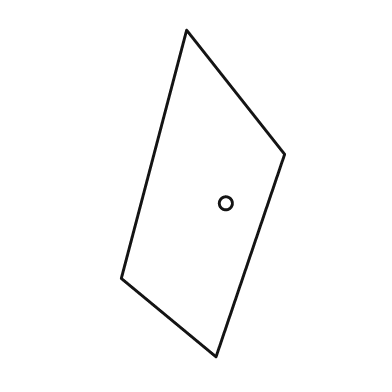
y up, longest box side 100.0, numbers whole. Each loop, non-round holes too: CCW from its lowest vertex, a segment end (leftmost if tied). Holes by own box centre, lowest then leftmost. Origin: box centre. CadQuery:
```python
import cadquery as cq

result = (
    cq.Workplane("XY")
    .moveTo(4.0, -50.0)
    .lineTo(25.0, 12.0)
    .lineTo(-5.0, 50.0)
    .lineTo(-25.0, -26.0)
    .close()
    .moveTo(7.0, -3.0)
    .circle(2.0)
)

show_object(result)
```